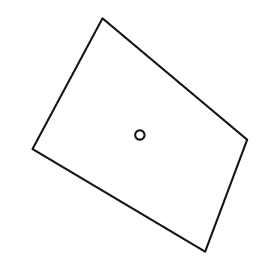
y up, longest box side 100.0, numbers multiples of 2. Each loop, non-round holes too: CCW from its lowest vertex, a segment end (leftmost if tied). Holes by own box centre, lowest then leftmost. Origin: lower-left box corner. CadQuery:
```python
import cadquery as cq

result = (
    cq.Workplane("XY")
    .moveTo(74.0, 0.0)
    .lineTo(92.0, 48.0)
    .lineTo(30.0, 100.0)
    .lineTo(0.0, 44.0)
    .close()
    .moveTo(46.0, 50.0)
    .circle(2.0)
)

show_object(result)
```